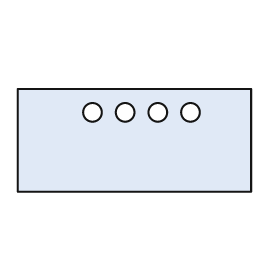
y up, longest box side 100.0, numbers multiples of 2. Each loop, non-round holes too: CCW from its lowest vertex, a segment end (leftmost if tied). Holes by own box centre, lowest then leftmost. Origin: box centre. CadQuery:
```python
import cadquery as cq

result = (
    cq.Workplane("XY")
    .moveTo(-50.0, -22.0)
    .lineTo(50.0, -22.0)
    .lineTo(50.0, 22.0)
    .lineTo(-50.0, 22.0)
    .close()
    .moveTo(-18.0, 12.0)
    .circle(4.0)
    .moveTo(-4.0, 12.0)
    .circle(4.0)
    .moveTo(10.0, 12.0)
    .circle(4.0)
    .moveTo(24.0, 12.0)
    .circle(4.0)
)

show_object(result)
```